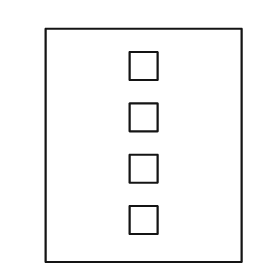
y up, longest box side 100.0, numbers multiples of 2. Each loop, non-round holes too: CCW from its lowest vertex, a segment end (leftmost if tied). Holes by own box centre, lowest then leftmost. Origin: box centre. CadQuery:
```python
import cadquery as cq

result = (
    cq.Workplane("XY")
    .moveTo(-42.0, -50.0)
    .lineTo(42.0, -50.0)
    .lineTo(42.0, 50.0)
    .lineTo(-42.0, 50.0)
    .close()
    .moveTo(-6.0, -38.0)
    .lineTo(6.0, -38.0)
    .lineTo(6.0, -26.0)
    .lineTo(-6.0, -26.0)
    .close()
    .moveTo(-6.0, -16.0)
    .lineTo(6.0, -16.0)
    .lineTo(6.0, -4.0)
    .lineTo(-6.0, -4.0)
    .close()
    .moveTo(-6.0, 6.0)
    .lineTo(6.0, 6.0)
    .lineTo(6.0, 18.0)
    .lineTo(-6.0, 18.0)
    .close()
    .moveTo(-6.0, 28.0)
    .lineTo(6.0, 28.0)
    .lineTo(6.0, 40.0)
    .lineTo(-6.0, 40.0)
    .close()
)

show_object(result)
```